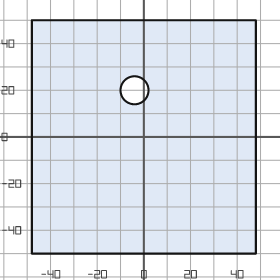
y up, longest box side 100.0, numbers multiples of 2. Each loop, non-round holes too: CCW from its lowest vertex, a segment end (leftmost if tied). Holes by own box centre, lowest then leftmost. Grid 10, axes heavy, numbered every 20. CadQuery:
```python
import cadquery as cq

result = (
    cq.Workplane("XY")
    .moveTo(-48.0, -50.0)
    .lineTo(48.0, -50.0)
    .lineTo(48.0, 50.0)
    .lineTo(-48.0, 50.0)
    .close()
    .moveTo(-4.0, 20.0)
    .circle(6.0)
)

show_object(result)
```